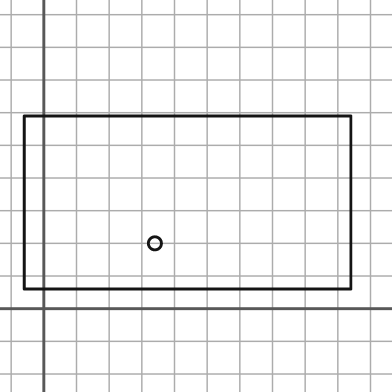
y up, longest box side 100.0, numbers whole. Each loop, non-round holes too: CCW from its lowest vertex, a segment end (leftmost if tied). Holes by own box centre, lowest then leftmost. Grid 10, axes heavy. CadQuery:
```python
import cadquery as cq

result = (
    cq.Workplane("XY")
    .moveTo(-6.0, 6.0)
    .lineTo(94.0, 6.0)
    .lineTo(94.0, 59.0)
    .lineTo(-6.0, 59.0)
    .close()
    .moveTo(34.0, 20.0)
    .circle(2.0)
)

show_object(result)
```